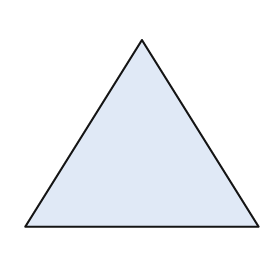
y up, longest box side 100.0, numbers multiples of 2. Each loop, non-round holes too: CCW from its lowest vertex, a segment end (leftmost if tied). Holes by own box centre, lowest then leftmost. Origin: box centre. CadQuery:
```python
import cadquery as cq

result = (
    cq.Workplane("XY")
    .moveTo(-50.0, -40.0)
    .lineTo(50.0, -40.0)
    .lineTo(0.0, 40.0)
    .close()
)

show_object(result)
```